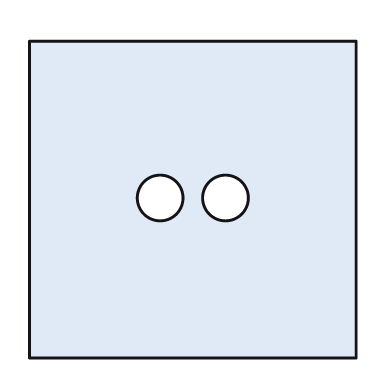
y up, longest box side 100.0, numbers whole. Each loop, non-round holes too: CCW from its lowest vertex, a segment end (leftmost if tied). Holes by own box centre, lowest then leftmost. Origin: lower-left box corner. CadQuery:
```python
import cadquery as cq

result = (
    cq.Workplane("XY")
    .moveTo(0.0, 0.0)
    .lineTo(100.0, 0.0)
    .lineTo(100.0, 97.0)
    .lineTo(0.0, 97.0)
    .close()
    .moveTo(40.0, 49.0)
    .circle(7.0)
    .moveTo(60.0, 49.0)
    .circle(7.0)
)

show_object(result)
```